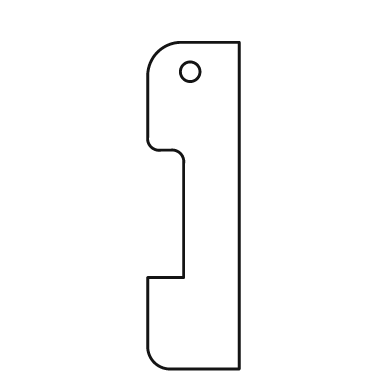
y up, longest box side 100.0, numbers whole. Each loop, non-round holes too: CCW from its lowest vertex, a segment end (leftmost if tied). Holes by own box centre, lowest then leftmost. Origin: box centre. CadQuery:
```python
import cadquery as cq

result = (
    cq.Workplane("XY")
    .moveTo(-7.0, -50.0)
    .lineTo(14.0, -50.0)
    .lineTo(14.0, 50.0)
    .lineTo(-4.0, 50.0)
    .threePointArc((-11.0, 47.0), (-14.0, 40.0))
    .lineTo(-14.0, 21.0)
    .threePointArc((-13.0, 18.0), (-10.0, 17.0))
    .lineTo(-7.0, 17.0)
    .threePointArc((-4.0, 16.0), (-3.0, 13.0))
    .lineTo(-3.0, -22.0)
    .lineTo(-14.0, -22.0)
    .lineTo(-14.0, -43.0)
    .threePointArc((-12.0, -48.0), (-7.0, -50.0))
    .close()
    .moveTo(-1.0, 41.0)
    .circle(3.0)
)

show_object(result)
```